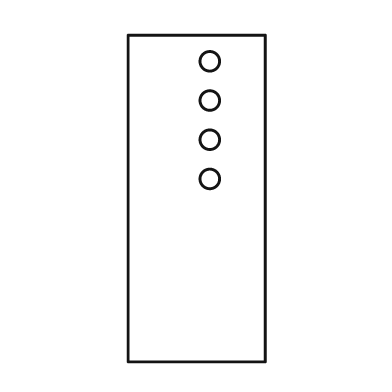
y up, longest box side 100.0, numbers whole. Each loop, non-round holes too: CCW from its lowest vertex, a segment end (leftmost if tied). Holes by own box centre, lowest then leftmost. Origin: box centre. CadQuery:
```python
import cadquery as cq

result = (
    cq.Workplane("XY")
    .moveTo(-21.0, -50.0)
    .lineTo(21.0, -50.0)
    .lineTo(21.0, 50.0)
    .lineTo(-21.0, 50.0)
    .close()
    .moveTo(4.0, 6.0)
    .circle(3.0)
    .moveTo(4.0, 18.0)
    .circle(3.0)
    .moveTo(4.0, 30.0)
    .circle(3.0)
    .moveTo(4.0, 42.0)
    .circle(3.0)
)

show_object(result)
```